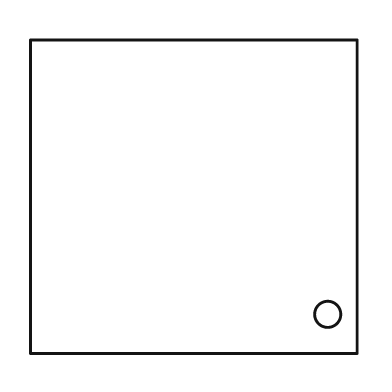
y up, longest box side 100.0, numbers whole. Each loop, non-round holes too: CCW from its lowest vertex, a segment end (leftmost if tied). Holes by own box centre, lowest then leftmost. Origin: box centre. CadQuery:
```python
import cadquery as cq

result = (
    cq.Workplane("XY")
    .moveTo(-50.0, -48.0)
    .lineTo(50.0, -48.0)
    .lineTo(50.0, 48.0)
    .lineTo(-50.0, 48.0)
    .close()
    .moveTo(41.0, -36.0)
    .circle(4.0)
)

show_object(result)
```